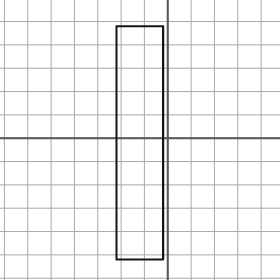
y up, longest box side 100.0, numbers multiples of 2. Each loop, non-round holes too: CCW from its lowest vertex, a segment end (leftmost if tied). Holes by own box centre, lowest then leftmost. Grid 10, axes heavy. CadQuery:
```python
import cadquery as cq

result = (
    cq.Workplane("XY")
    .moveTo(-22.0, -52.0)
    .lineTo(-2.0, -52.0)
    .lineTo(-2.0, 48.0)
    .lineTo(-22.0, 48.0)
    .close()
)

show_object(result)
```